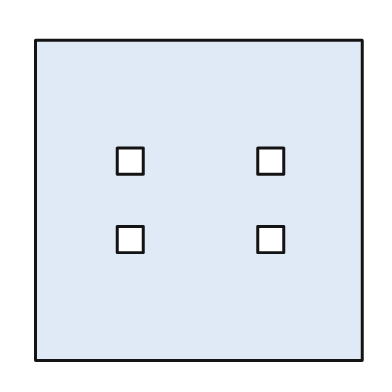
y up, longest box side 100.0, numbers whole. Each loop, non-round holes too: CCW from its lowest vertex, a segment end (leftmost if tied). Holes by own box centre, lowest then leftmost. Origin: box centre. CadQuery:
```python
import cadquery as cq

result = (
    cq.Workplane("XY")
    .moveTo(-50.0, -49.0)
    .lineTo(50.0, -49.0)
    .lineTo(50.0, 49.0)
    .lineTo(-50.0, 49.0)
    .close()
    .moveTo(-25.0, -16.0)
    .lineTo(-17.0, -16.0)
    .lineTo(-17.0, -8.0)
    .lineTo(-25.0, -8.0)
    .close()
    .moveTo(18.0, -16.0)
    .lineTo(26.0, -16.0)
    .lineTo(26.0, -8.0)
    .lineTo(18.0, -8.0)
    .close()
    .moveTo(-25.0, 8.0)
    .lineTo(-17.0, 8.0)
    .lineTo(-17.0, 16.0)
    .lineTo(-25.0, 16.0)
    .close()
    .moveTo(18.0, 8.0)
    .lineTo(26.0, 8.0)
    .lineTo(26.0, 16.0)
    .lineTo(18.0, 16.0)
    .close()
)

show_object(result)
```